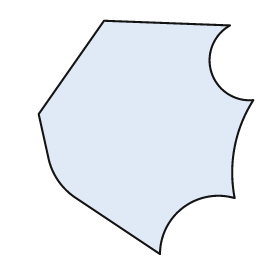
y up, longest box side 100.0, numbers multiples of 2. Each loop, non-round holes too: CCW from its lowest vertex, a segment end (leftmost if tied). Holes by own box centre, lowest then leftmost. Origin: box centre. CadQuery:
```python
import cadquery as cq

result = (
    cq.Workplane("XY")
    .moveTo(6.0, -50.0)
    .threePointArc((16.0, -30.0), (38.0, -26.0))
    .threePointArc((38.0, -4.0), (46.0, 16.0))
    .threePointArc((28.0, 28.0), (36.0, 48.0))
    .lineTo(-18.0, 50.0)
    .lineTo(-46.0, 10.0)
    .lineTo(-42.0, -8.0)
    .threePointArc((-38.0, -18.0), (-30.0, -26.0))
    .close()
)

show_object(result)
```